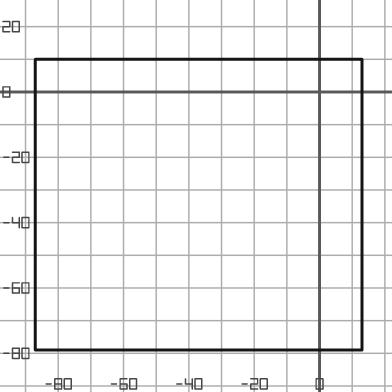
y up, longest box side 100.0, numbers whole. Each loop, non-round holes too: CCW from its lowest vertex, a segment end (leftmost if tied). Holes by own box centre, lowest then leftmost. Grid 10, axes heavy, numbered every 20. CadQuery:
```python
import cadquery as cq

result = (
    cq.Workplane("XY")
    .moveTo(-87.0, -79.0)
    .lineTo(13.0, -79.0)
    .lineTo(13.0, 10.0)
    .lineTo(-87.0, 10.0)
    .close()
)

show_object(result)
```